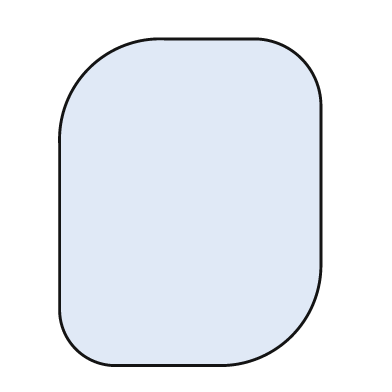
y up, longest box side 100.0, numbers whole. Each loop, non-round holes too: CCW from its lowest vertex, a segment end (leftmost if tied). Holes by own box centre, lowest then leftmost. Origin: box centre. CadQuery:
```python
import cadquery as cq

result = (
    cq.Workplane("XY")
    .moveTo(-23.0, -50.0)
    .lineTo(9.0, -50.0)
    .threePointArc((31.0, -41.0), (40.0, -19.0))
    .lineTo(40.0, 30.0)
    .threePointArc((34.0, 44.0), (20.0, 50.0))
    .lineTo(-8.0, 50.0)
    .threePointArc((-31.0, 41.0), (-40.0, 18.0))
    .lineTo(-40.0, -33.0)
    .threePointArc((-35.0, -45.0), (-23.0, -50.0))
    .close()
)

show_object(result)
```